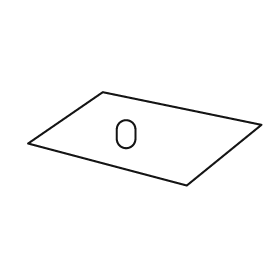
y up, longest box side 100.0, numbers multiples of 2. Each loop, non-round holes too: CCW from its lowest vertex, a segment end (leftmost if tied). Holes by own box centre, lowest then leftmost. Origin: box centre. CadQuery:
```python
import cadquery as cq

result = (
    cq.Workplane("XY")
    .moveTo(18.0, -20.0)
    .lineTo(50.0, 6.0)
    .lineTo(-18.0, 20.0)
    .lineTo(-50.0, -2.0)
    .close()
    .moveTo(-12.0, 0.0)
    .threePointArc((-8.0, -4.0), (-4.0, 0.0))
    .lineTo(-4.0, 4.0)
    .threePointArc((-8.0, 8.0), (-12.0, 4.0))
    .close()
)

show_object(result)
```